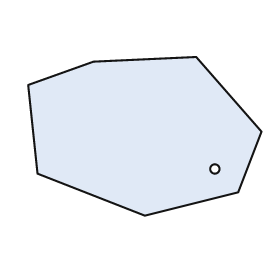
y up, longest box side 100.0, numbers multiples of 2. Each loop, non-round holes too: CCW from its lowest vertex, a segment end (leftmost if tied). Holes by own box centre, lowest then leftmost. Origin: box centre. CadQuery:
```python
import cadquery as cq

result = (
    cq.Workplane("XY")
    .moveTo(0.0, -34.0)
    .lineTo(40.0, -24.0)
    .lineTo(50.0, 2.0)
    .lineTo(22.0, 34.0)
    .lineTo(-22.0, 32.0)
    .lineTo(-50.0, 22.0)
    .lineTo(-46.0, -16.0)
    .close()
    .moveTo(30.0, -14.0)
    .circle(2.0)
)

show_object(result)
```